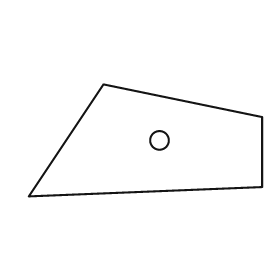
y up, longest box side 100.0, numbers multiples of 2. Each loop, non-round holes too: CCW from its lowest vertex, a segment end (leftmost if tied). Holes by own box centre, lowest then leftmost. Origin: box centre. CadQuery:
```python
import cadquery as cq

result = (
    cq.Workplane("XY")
    .moveTo(-50.0, -24.0)
    .lineTo(50.0, -20.0)
    .lineTo(50.0, 10.0)
    .lineTo(-18.0, 24.0)
    .close()
    .moveTo(6.0, 0.0)
    .circle(4.0)
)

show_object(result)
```